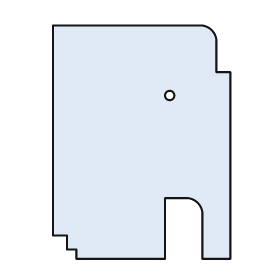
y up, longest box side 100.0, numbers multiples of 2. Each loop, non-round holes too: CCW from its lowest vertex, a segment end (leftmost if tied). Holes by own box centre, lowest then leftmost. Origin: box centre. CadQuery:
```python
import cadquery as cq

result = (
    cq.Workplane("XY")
    .moveTo(-28.0, -50.0)
    .lineTo(10.0, -50.0)
    .lineTo(10.0, -24.0)
    .lineTo(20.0, -24.0)
    .threePointArc((24.0, -26.0), (26.0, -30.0))
    .lineTo(26.0, -50.0)
    .lineTo(38.0, -50.0)
    .lineTo(38.0, 30.0)
    .lineTo(32.0, 30.0)
    .lineTo(32.0, 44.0)
    .threePointArc((30.0, 48.0), (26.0, 50.0))
    .lineTo(-38.0, 50.0)
    .lineTo(-38.0, -40.0)
    .lineTo(-32.0, -40.0)
    .lineTo(-32.0, -46.0)
    .lineTo(-28.0, -46.0)
    .close()
    .moveTo(12.0, 20.0)
    .circle(2.0)
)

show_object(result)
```